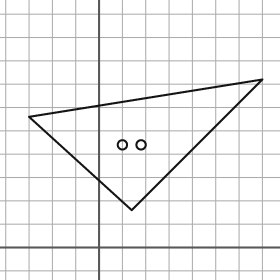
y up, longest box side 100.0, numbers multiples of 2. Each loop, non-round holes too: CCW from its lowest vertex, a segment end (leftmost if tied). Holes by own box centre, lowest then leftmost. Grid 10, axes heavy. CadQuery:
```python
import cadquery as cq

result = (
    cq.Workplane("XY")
    .moveTo(14.0, 16.0)
    .lineTo(70.0, 72.0)
    .lineTo(-30.0, 56.0)
    .close()
    .moveTo(10.0, 44.0)
    .circle(2.0)
    .moveTo(18.0, 44.0)
    .circle(2.0)
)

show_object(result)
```